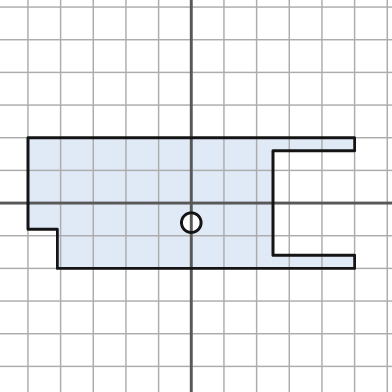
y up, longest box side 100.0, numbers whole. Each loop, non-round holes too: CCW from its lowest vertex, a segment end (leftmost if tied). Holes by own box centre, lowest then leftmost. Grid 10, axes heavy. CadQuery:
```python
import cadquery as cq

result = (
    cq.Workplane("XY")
    .moveTo(-41.0, -20.0)
    .lineTo(50.0, -20.0)
    .lineTo(50.0, -16.0)
    .lineTo(25.0, -16.0)
    .lineTo(25.0, 16.0)
    .lineTo(50.0, 16.0)
    .lineTo(50.0, 20.0)
    .lineTo(-50.0, 20.0)
    .lineTo(-50.0, -8.0)
    .lineTo(-41.0, -8.0)
    .close()
    .moveTo(0.0, -6.0)
    .circle(3.0)
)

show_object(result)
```